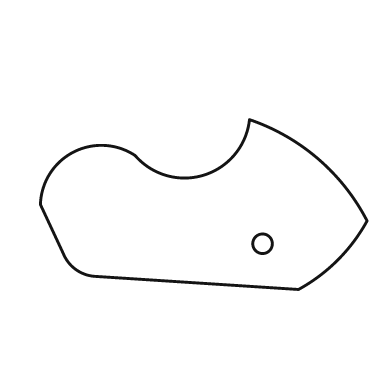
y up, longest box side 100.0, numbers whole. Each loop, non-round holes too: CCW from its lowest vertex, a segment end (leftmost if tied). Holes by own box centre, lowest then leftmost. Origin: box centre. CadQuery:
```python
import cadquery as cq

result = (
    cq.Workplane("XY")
    .moveTo(29.0, -26.0)
    .threePointArc((41.0, -17.0), (50.0, -5.0))
    .threePointArc((35.0, 14.0), (14.0, 26.0))
    .threePointArc((0.0, 9.0), (-21.0, 15.0))
    .threePointArc((-40.0, 16.0), (-50.0, 0.0))
    .lineTo(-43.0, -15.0)
    .threePointArc((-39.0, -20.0), (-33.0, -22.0))
    .close()
    .moveTo(18.0, -12.0)
    .circle(3.0)
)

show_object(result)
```